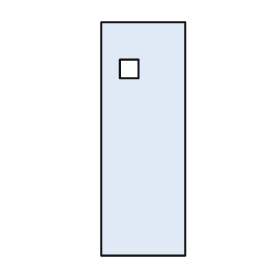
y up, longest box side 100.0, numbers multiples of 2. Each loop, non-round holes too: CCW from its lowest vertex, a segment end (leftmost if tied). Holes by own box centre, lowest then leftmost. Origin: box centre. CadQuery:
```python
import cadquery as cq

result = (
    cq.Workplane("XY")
    .moveTo(-18.0, -50.0)
    .lineTo(18.0, -50.0)
    .lineTo(18.0, 50.0)
    .lineTo(-18.0, 50.0)
    .close()
    .moveTo(-10.0, 26.0)
    .lineTo(-2.0, 26.0)
    .lineTo(-2.0, 34.0)
    .lineTo(-10.0, 34.0)
    .close()
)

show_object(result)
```